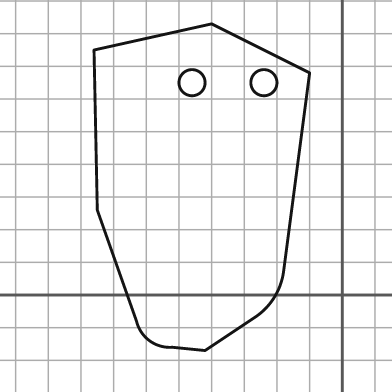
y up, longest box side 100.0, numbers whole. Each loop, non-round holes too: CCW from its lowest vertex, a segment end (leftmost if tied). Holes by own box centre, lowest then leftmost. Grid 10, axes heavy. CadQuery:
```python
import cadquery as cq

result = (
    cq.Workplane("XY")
    .moveTo(-42.0, -17.0)
    .lineTo(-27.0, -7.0)
    .threePointArc((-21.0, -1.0), (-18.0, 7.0))
    .lineTo(-10.0, 68.0)
    .lineTo(-40.0, 83.0)
    .lineTo(-76.0, 75.0)
    .lineTo(-75.0, 26.0)
    .lineTo(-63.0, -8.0)
    .threePointArc((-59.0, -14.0), (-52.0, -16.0))
    .close()
    .moveTo(-46.0, 65.0)
    .circle(4.0)
    .moveTo(-24.0, 65.0)
    .circle(4.0)
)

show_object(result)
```